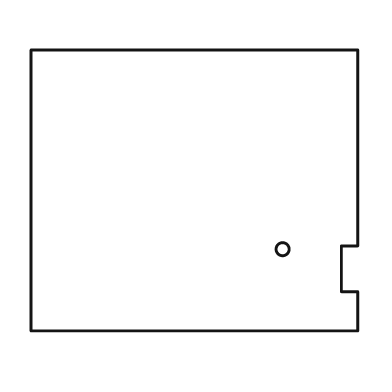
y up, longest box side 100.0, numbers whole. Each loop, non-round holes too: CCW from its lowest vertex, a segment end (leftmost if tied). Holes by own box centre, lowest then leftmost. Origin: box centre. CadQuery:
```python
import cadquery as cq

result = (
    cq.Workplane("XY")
    .moveTo(-50.0, -43.0)
    .lineTo(50.0, -43.0)
    .lineTo(50.0, -31.0)
    .lineTo(45.0, -31.0)
    .lineTo(45.0, -17.0)
    .lineTo(50.0, -17.0)
    .lineTo(50.0, 43.0)
    .lineTo(-50.0, 43.0)
    .close()
    .moveTo(27.0, -18.0)
    .circle(2.0)
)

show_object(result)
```